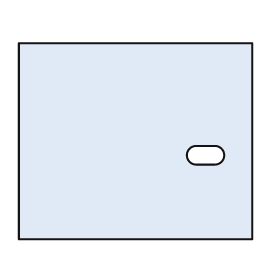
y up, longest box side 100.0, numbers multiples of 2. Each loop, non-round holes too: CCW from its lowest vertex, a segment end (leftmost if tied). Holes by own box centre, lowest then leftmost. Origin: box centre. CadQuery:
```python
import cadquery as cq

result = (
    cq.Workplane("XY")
    .moveTo(-50.0, -42.0)
    .lineTo(50.0, -42.0)
    .lineTo(50.0, 42.0)
    .lineTo(-50.0, 42.0)
    .close()
    .moveTo(26.0, -10.0)
    .lineTo(34.0, -10.0)
    .threePointArc((38.0, -6.0), (34.0, -2.0))
    .lineTo(26.0, -2.0)
    .threePointArc((22.0, -6.0), (26.0, -10.0))
    .close()
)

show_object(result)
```